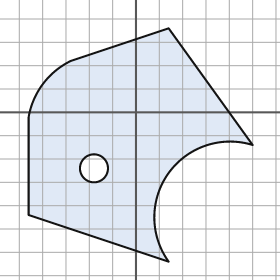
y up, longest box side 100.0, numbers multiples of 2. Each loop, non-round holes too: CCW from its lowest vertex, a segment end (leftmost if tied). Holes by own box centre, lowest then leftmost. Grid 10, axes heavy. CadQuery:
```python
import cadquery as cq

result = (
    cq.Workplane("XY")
    .moveTo(14.0, -64.0)
    .threePointArc((14.0, -26.0), (50.0, -14.0))
    .lineTo(14.0, 36.0)
    .lineTo(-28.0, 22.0)
    .threePointArc((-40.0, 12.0), (-46.0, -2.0))
    .lineTo(-46.0, -44.0)
    .close()
    .moveTo(-18.0, -24.0)
    .circle(6.0)
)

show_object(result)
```